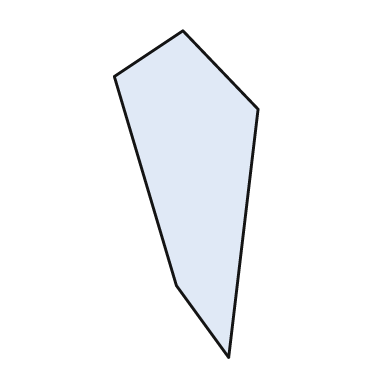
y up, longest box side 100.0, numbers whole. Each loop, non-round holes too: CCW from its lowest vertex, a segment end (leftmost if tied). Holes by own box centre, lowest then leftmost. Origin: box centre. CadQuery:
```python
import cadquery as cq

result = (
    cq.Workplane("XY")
    .moveTo(13.0, -50.0)
    .lineTo(22.0, 26.0)
    .lineTo(-1.0, 50.0)
    .lineTo(-22.0, 36.0)
    .lineTo(-3.0, -28.0)
    .close()
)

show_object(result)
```